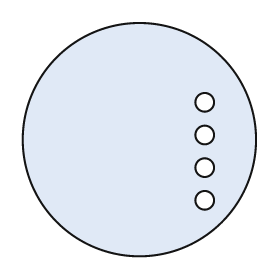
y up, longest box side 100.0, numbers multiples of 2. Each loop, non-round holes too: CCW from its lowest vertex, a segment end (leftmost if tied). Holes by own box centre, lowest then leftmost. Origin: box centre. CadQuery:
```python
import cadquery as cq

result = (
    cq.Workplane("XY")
    .moveTo(0.0, 0.0)
    .circle(50.0)
    .moveTo(28.0, -26.0)
    .circle(4.0)
    .moveTo(28.0, -12.0)
    .circle(4.0)
    .moveTo(28.0, 2.0)
    .circle(4.0)
    .moveTo(28.0, 16.0)
    .circle(4.0)
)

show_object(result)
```